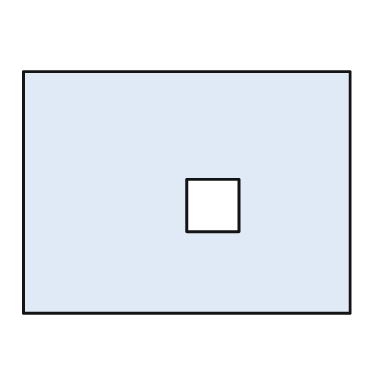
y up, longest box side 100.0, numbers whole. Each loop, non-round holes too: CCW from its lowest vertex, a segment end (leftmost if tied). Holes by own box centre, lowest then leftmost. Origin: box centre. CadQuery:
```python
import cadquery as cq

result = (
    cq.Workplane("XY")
    .moveTo(-50.0, -37.0)
    .lineTo(50.0, -37.0)
    .lineTo(50.0, 37.0)
    .lineTo(-50.0, 37.0)
    .close()
    .moveTo(0.0, -12.0)
    .lineTo(16.0, -12.0)
    .lineTo(16.0, 4.0)
    .lineTo(0.0, 4.0)
    .close()
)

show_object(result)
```